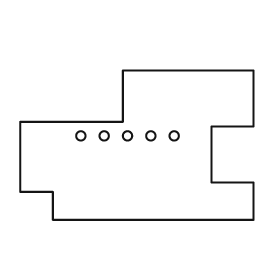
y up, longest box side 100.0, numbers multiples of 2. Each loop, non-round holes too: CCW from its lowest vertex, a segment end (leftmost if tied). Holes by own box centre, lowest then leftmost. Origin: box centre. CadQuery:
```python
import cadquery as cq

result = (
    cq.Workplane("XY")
    .moveTo(-36.0, -32.0)
    .lineTo(50.0, -32.0)
    .lineTo(50.0, -16.0)
    .lineTo(32.0, -16.0)
    .lineTo(32.0, 8.0)
    .lineTo(50.0, 8.0)
    .lineTo(50.0, 32.0)
    .lineTo(-6.0, 32.0)
    .lineTo(-6.0, 10.0)
    .lineTo(-50.0, 10.0)
    .lineTo(-50.0, -20.0)
    .lineTo(-36.0, -20.0)
    .close()
    .moveTo(-24.0, 4.0)
    .circle(2.0)
    .moveTo(-14.0, 4.0)
    .circle(2.0)
    .moveTo(-4.0, 4.0)
    .circle(2.0)
    .moveTo(6.0, 4.0)
    .circle(2.0)
    .moveTo(16.0, 4.0)
    .circle(2.0)
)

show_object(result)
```